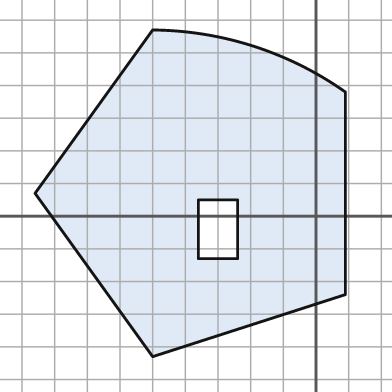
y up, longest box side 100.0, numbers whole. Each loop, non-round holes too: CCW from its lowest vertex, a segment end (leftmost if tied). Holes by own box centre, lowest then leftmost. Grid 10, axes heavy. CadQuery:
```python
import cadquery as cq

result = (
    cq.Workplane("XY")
    .moveTo(-50.0, -43.0)
    .lineTo(9.0, -24.0)
    .lineTo(9.0, 38.0)
    .threePointArc((-19.0, 52.0), (-50.0, 57.0))
    .lineTo(-86.0, 7.0)
    .close()
    .moveTo(-36.0, -13.0)
    .lineTo(-24.0, -13.0)
    .lineTo(-24.0, 5.0)
    .lineTo(-36.0, 5.0)
    .close()
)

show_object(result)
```